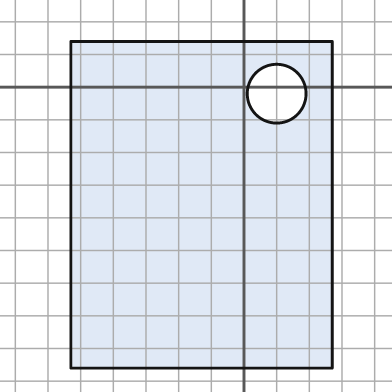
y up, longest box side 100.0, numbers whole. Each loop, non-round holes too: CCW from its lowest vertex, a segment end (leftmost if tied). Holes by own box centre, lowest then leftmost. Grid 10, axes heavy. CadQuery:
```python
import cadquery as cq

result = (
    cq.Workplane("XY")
    .moveTo(-53.0, -86.0)
    .lineTo(27.0, -86.0)
    .lineTo(27.0, 14.0)
    .lineTo(-53.0, 14.0)
    .close()
    .moveTo(10.0, -2.0)
    .circle(9.0)
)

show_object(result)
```